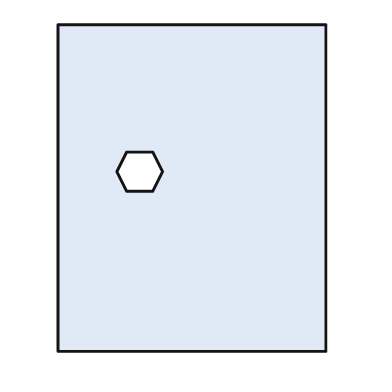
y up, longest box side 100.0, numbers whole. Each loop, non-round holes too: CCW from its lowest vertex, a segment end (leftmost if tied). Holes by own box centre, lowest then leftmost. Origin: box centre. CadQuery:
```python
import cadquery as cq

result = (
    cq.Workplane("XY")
    .moveTo(-41.0, -50.0)
    .lineTo(41.0, -50.0)
    .lineTo(41.0, 50.0)
    .lineTo(-41.0, 50.0)
    .close()
    .moveTo(-20.0, -1.0)
    .lineTo(-12.0, -1.0)
    .lineTo(-9.0, 5.0)
    .lineTo(-12.0, 11.0)
    .lineTo(-20.0, 11.0)
    .lineTo(-23.0, 5.0)
    .close()
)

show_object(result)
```